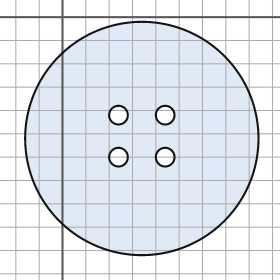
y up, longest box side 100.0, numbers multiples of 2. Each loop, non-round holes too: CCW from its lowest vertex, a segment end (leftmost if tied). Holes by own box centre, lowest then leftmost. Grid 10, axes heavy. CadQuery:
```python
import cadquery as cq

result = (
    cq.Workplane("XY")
    .moveTo(34.0, -52.0)
    .circle(50.0)
    .moveTo(24.0, -60.0)
    .circle(4.0)
    .moveTo(44.0, -60.0)
    .circle(4.0)
    .moveTo(24.0, -42.0)
    .circle(4.0)
    .moveTo(44.0, -42.0)
    .circle(4.0)
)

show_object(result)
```